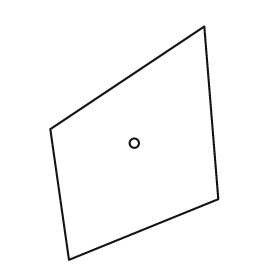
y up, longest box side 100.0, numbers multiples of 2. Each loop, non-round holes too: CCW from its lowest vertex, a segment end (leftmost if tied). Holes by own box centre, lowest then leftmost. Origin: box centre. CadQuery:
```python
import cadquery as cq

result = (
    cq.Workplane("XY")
    .moveTo(-28.0, -50.0)
    .lineTo(36.0, -24.0)
    .lineTo(30.0, 50.0)
    .lineTo(-36.0, 6.0)
    .close()
    .moveTo(0.0, 0.0)
    .circle(2.0)
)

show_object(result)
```